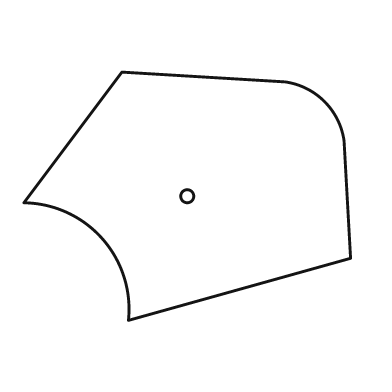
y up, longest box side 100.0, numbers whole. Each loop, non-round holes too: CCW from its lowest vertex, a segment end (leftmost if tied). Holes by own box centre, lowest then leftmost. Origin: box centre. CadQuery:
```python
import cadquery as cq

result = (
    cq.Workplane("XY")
    .moveTo(-18.0, -38.0)
    .lineTo(50.0, -19.0)
    .lineTo(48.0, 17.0)
    .threePointArc((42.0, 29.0), (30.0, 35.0))
    .lineTo(-20.0, 38.0)
    .lineTo(-50.0, -2.0)
    .threePointArc((-26.0, -13.0), (-18.0, -38.0))
    .close()
    .moveTo(0.0, 0.0)
    .circle(2.0)
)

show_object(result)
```